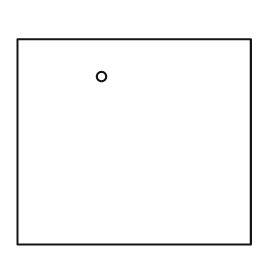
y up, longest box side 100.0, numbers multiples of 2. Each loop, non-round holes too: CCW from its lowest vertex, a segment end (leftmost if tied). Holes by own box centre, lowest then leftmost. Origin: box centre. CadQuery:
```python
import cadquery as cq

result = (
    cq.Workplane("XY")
    .moveTo(-50.0, -44.0)
    .lineTo(50.0, -44.0)
    .lineTo(50.0, 44.0)
    .lineTo(-50.0, 44.0)
    .close()
    .moveTo(-14.0, 28.0)
    .circle(2.0)
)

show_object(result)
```